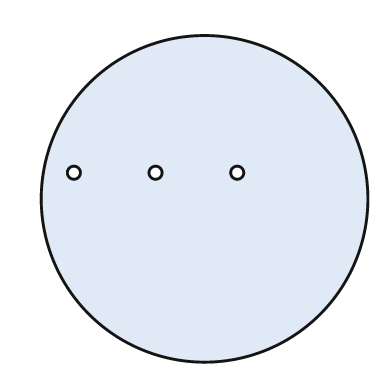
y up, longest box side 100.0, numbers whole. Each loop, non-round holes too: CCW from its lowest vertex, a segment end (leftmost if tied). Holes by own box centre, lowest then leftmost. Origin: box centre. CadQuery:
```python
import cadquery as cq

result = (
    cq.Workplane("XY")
    .moveTo(0.0, 0.0)
    .circle(50.0)
    .moveTo(-40.0, 8.0)
    .circle(2.0)
    .moveTo(-15.0, 8.0)
    .circle(2.0)
    .moveTo(10.0, 8.0)
    .circle(2.0)
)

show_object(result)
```